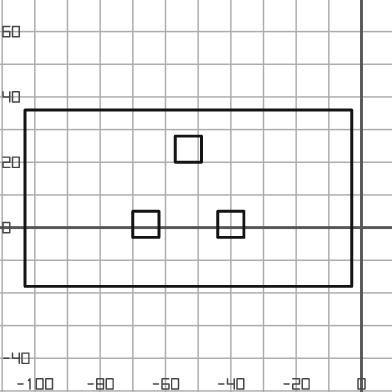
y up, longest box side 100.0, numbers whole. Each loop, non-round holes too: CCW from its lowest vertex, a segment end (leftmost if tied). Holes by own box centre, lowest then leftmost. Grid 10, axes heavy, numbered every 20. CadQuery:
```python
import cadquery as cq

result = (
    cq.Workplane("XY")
    .moveTo(-103.0, -18.0)
    .lineTo(-3.0, -18.0)
    .lineTo(-3.0, 36.0)
    .lineTo(-103.0, 36.0)
    .close()
    .moveTo(-70.0, -3.0)
    .lineTo(-62.0, -3.0)
    .lineTo(-62.0, 5.0)
    .lineTo(-70.0, 5.0)
    .close()
    .moveTo(-44.0, -3.0)
    .lineTo(-36.0, -3.0)
    .lineTo(-36.0, 5.0)
    .lineTo(-44.0, 5.0)
    .close()
    .moveTo(-57.0, 20.0)
    .lineTo(-49.0, 20.0)
    .lineTo(-49.0, 28.0)
    .lineTo(-57.0, 28.0)
    .close()
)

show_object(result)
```